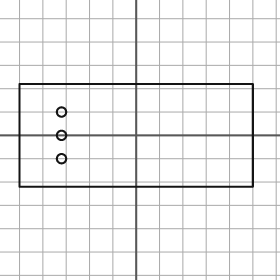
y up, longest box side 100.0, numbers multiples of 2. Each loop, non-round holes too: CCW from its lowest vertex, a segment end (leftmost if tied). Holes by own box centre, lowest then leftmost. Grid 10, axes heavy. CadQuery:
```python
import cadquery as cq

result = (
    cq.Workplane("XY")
    .moveTo(-50.0, -22.0)
    .lineTo(50.0, -22.0)
    .lineTo(50.0, 22.0)
    .lineTo(-50.0, 22.0)
    .close()
    .moveTo(-32.0, -10.0)
    .circle(2.0)
    .moveTo(-32.0, 0.0)
    .circle(2.0)
    .moveTo(-32.0, 10.0)
    .circle(2.0)
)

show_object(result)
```